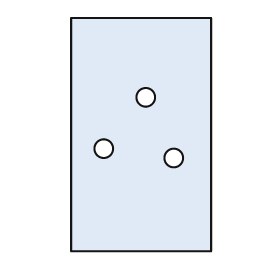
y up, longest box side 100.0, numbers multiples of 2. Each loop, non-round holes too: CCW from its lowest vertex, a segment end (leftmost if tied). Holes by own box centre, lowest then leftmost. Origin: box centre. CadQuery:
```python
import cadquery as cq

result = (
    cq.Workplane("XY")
    .moveTo(-30.0, -50.0)
    .lineTo(30.0, -50.0)
    .lineTo(30.0, 50.0)
    .lineTo(-30.0, 50.0)
    .close()
    .moveTo(14.0, -10.0)
    .circle(4.0)
    .moveTo(-16.0, -6.0)
    .circle(4.0)
    .moveTo(2.0, 16.0)
    .circle(4.0)
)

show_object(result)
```